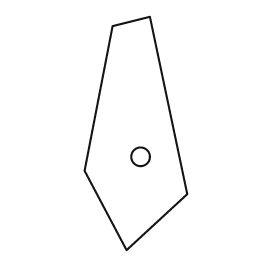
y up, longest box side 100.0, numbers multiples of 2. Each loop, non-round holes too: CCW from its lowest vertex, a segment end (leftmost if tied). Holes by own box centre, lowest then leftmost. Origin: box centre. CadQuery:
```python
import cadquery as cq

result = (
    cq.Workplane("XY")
    .moveTo(-4.0, -50.0)
    .lineTo(22.0, -26.0)
    .lineTo(6.0, 50.0)
    .lineTo(-10.0, 46.0)
    .lineTo(-22.0, -16.0)
    .close()
    .moveTo(2.0, -10.0)
    .circle(4.0)
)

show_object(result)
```